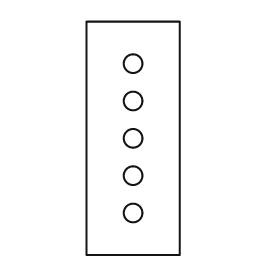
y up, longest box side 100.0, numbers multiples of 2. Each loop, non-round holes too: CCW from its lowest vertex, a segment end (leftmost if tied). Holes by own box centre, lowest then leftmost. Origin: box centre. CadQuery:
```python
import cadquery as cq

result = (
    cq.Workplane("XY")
    .moveTo(-20.0, -50.0)
    .lineTo(20.0, -50.0)
    .lineTo(20.0, 50.0)
    .lineTo(-20.0, 50.0)
    .close()
    .moveTo(0.0, -32.0)
    .circle(4.0)
    .moveTo(0.0, -16.0)
    .circle(4.0)
    .moveTo(0.0, 0.0)
    .circle(4.0)
    .moveTo(0.0, 16.0)
    .circle(4.0)
    .moveTo(0.0, 32.0)
    .circle(4.0)
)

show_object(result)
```